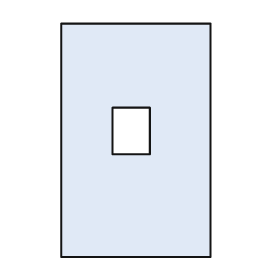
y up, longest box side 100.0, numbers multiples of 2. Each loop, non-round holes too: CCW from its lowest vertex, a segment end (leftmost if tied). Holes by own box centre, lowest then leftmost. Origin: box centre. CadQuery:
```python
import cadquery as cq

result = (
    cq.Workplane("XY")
    .moveTo(-32.0, -50.0)
    .lineTo(32.0, -50.0)
    .lineTo(32.0, 50.0)
    .lineTo(-32.0, 50.0)
    .close()
    .moveTo(-10.0, -6.0)
    .lineTo(6.0, -6.0)
    .lineTo(6.0, 14.0)
    .lineTo(-10.0, 14.0)
    .close()
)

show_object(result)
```